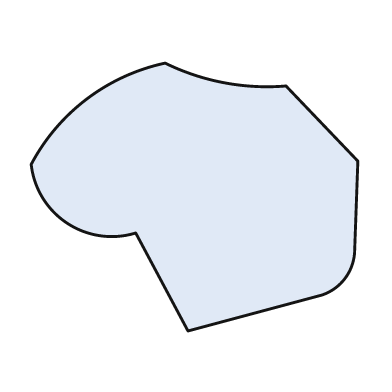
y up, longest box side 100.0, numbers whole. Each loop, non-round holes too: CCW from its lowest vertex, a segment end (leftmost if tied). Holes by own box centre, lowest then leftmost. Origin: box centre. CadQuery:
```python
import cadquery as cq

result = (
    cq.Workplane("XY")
    .moveTo(-2.0, -41.0)
    .lineTo(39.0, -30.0)
    .threePointArc((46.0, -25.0), (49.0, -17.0))
    .lineTo(50.0, 11.0)
    .lineTo(28.0, 34.0)
    .threePointArc((9.0, 35.0), (-9.0, 41.0))
    .threePointArc((-33.0, 30.0), (-50.0, 10.0))
    .threePointArc((-39.0, -8.0), (-18.0, -11.0))
    .close()
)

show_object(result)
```